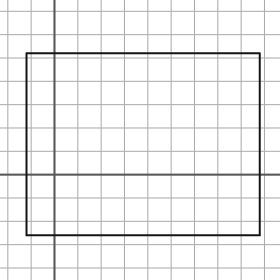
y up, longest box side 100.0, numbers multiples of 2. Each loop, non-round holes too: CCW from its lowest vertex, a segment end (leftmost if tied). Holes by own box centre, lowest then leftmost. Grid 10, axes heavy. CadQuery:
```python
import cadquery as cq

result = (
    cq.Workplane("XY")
    .moveTo(-12.0, -26.0)
    .lineTo(88.0, -26.0)
    .lineTo(88.0, 52.0)
    .lineTo(-12.0, 52.0)
    .close()
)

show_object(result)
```